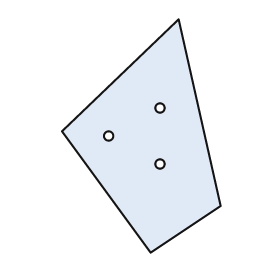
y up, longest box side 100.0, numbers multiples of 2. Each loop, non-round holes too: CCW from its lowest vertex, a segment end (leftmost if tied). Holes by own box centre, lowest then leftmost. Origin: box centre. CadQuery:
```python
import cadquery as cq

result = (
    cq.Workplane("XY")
    .moveTo(4.0, -50.0)
    .lineTo(34.0, -30.0)
    .lineTo(16.0, 50.0)
    .lineTo(-34.0, 2.0)
    .close()
    .moveTo(8.0, -12.0)
    .circle(2.0)
    .moveTo(-14.0, 0.0)
    .circle(2.0)
    .moveTo(8.0, 12.0)
    .circle(2.0)
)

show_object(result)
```